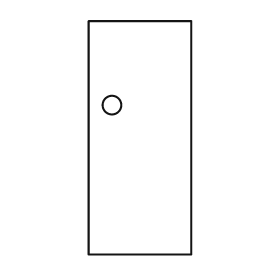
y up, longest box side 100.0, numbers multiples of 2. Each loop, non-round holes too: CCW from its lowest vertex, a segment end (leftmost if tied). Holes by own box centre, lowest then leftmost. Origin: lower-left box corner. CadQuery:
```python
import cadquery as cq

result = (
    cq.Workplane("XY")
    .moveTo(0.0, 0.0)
    .lineTo(44.0, 0.0)
    .lineTo(44.0, 100.0)
    .lineTo(0.0, 100.0)
    .close()
    .moveTo(10.0, 64.0)
    .circle(4.0)
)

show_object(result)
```